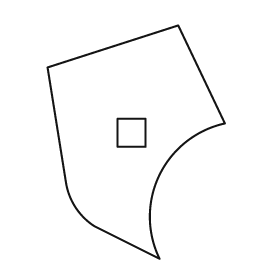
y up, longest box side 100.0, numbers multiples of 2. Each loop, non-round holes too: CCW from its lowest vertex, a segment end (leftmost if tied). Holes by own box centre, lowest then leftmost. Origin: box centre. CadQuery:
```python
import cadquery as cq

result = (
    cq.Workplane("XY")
    .moveTo(10.0, -50.0)
    .threePointArc((10.0, -14.0), (38.0, 8.0))
    .lineTo(18.0, 50.0)
    .lineTo(-38.0, 32.0)
    .lineTo(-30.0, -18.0)
    .threePointArc((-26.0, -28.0), (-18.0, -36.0))
    .close()
    .moveTo(-8.0, -2.0)
    .lineTo(4.0, -2.0)
    .lineTo(4.0, 10.0)
    .lineTo(-8.0, 10.0)
    .close()
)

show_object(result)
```